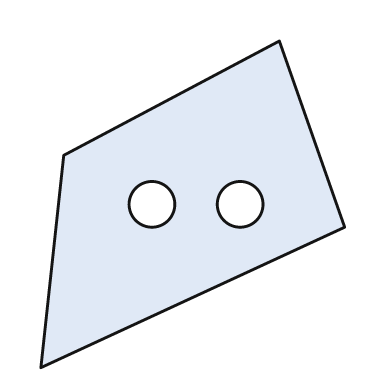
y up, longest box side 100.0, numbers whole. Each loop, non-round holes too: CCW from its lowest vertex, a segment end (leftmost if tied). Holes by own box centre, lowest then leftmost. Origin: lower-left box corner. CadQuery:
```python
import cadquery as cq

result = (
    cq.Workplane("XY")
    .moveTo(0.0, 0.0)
    .lineTo(93.0, 43.0)
    .lineTo(73.0, 100.0)
    .lineTo(7.0, 65.0)
    .close()
    .moveTo(34.0, 50.0)
    .circle(7.0)
    .moveTo(61.0, 50.0)
    .circle(7.0)
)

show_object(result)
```